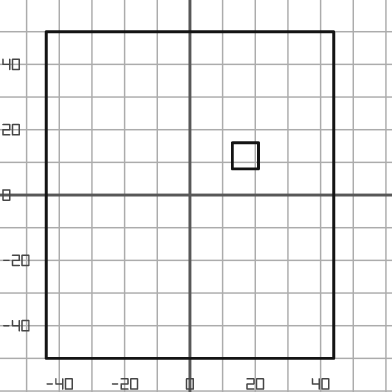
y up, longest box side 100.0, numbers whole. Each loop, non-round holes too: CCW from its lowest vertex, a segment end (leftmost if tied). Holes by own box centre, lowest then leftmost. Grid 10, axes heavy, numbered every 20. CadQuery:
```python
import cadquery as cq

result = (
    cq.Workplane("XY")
    .moveTo(-44.0, -50.0)
    .lineTo(44.0, -50.0)
    .lineTo(44.0, 50.0)
    .lineTo(-44.0, 50.0)
    .close()
    .moveTo(13.0, 8.0)
    .lineTo(21.0, 8.0)
    .lineTo(21.0, 16.0)
    .lineTo(13.0, 16.0)
    .close()
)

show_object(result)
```